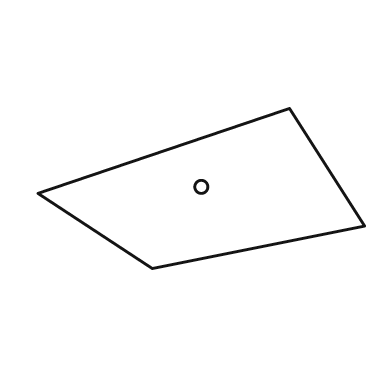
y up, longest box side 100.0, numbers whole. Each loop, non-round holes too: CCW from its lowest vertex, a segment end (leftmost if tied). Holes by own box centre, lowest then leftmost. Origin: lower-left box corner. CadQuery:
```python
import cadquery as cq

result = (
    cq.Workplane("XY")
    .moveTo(35.0, 0.0)
    .lineTo(100.0, 13.0)
    .lineTo(77.0, 49.0)
    .lineTo(0.0, 23.0)
    .close()
    .moveTo(50.0, 25.0)
    .circle(2.0)
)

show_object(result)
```